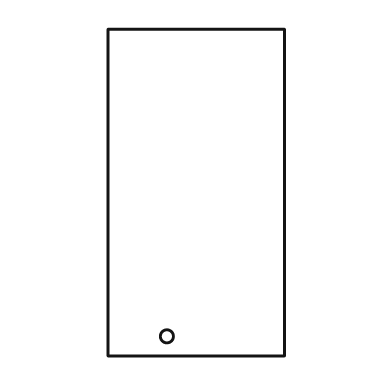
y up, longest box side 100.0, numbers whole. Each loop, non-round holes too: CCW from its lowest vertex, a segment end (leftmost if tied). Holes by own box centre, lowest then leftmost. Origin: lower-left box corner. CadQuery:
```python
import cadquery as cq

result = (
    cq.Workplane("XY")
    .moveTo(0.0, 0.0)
    .lineTo(54.0, 0.0)
    .lineTo(54.0, 100.0)
    .lineTo(0.0, 100.0)
    .close()
    .moveTo(18.0, 6.0)
    .circle(2.0)
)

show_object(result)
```